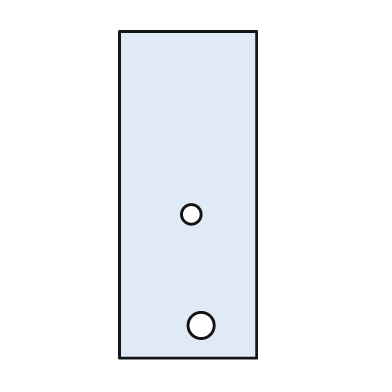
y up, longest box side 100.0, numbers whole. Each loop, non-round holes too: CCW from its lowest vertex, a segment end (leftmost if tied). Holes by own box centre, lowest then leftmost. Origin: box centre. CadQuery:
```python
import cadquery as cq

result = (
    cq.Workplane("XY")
    .moveTo(-21.0, -50.0)
    .lineTo(21.0, -50.0)
    .lineTo(21.0, 50.0)
    .lineTo(-21.0, 50.0)
    .close()
    .moveTo(4.0, -40.0)
    .circle(4.0)
    .moveTo(1.0, -6.0)
    .circle(3.0)
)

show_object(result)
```